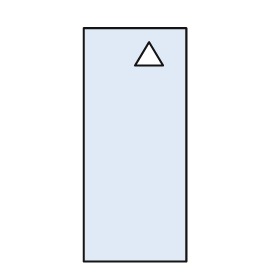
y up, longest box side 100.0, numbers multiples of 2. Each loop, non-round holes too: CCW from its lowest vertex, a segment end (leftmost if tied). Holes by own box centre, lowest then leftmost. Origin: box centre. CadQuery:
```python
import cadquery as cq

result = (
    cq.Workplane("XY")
    .moveTo(-22.0, -50.0)
    .lineTo(22.0, -50.0)
    .lineTo(22.0, 50.0)
    .lineTo(-22.0, 50.0)
    .close()
    .moveTo(0.0, 34.0)
    .lineTo(12.0, 34.0)
    .lineTo(6.0, 44.0)
    .close()
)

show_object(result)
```